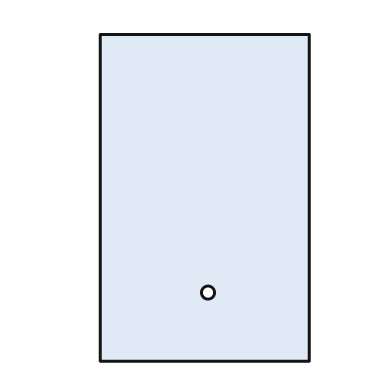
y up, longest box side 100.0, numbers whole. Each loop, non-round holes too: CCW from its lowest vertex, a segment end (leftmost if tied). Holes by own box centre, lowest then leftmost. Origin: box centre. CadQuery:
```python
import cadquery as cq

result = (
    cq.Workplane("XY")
    .moveTo(-32.0, -50.0)
    .lineTo(32.0, -50.0)
    .lineTo(32.0, 50.0)
    .lineTo(-32.0, 50.0)
    .close()
    .moveTo(1.0, -29.0)
    .circle(2.0)
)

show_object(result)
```